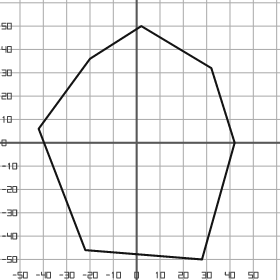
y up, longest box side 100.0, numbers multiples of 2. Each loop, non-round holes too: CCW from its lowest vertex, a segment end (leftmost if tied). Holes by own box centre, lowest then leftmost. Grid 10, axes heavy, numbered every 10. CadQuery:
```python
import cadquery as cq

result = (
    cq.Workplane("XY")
    .moveTo(28.0, -50.0)
    .lineTo(42.0, 0.0)
    .lineTo(32.0, 32.0)
    .lineTo(2.0, 50.0)
    .lineTo(-20.0, 36.0)
    .lineTo(-42.0, 6.0)
    .lineTo(-22.0, -46.0)
    .close()
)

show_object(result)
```